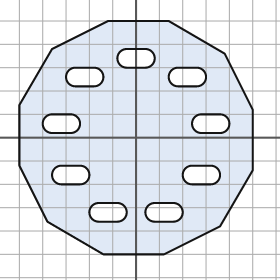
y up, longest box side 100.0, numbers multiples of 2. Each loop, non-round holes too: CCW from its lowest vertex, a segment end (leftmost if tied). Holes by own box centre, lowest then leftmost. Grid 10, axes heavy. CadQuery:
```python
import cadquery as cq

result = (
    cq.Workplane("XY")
    .moveTo(-14.0, -50.0)
    .lineTo(12.0, -50.0)
    .lineTo(36.0, -38.0)
    .lineTo(50.0, -14.0)
    .lineTo(50.0, 12.0)
    .lineTo(38.0, 36.0)
    .lineTo(14.0, 50.0)
    .lineTo(-12.0, 50.0)
    .lineTo(-36.0, 38.0)
    .lineTo(-50.0, 14.0)
    .lineTo(-50.0, -12.0)
    .lineTo(-38.0, -36.0)
    .close()
    .moveTo(-16.0, -36.0)
    .lineTo(-8.0, -36.0)
    .threePointArc((-4.0, -32.0), (-8.0, -28.0))
    .lineTo(-16.0, -28.0)
    .threePointArc((-20.0, -32.0), (-16.0, -36.0))
    .close()
    .moveTo(8.0, -36.0)
    .lineTo(16.0, -36.0)
    .threePointArc((20.0, -32.0), (16.0, -28.0))
    .lineTo(8.0, -28.0)
    .threePointArc((4.0, -32.0), (8.0, -36.0))
    .close()
    .moveTo(-32.0, -20.0)
    .lineTo(-24.0, -20.0)
    .threePointArc((-20.0, -16.0), (-24.0, -12.0))
    .lineTo(-32.0, -12.0)
    .threePointArc((-36.0, -16.0), (-32.0, -20.0))
    .close()
    .moveTo(24.0, -20.0)
    .lineTo(32.0, -20.0)
    .threePointArc((36.0, -16.0), (32.0, -12.0))
    .lineTo(24.0, -12.0)
    .threePointArc((20.0, -16.0), (24.0, -20.0))
    .close()
    .moveTo(-36.0, 2.0)
    .lineTo(-28.0, 2.0)
    .threePointArc((-24.0, 6.0), (-28.0, 10.0))
    .lineTo(-36.0, 10.0)
    .threePointArc((-40.0, 6.0), (-36.0, 2.0))
    .close()
    .moveTo(28.0, 2.0)
    .lineTo(36.0, 2.0)
    .threePointArc((40.0, 6.0), (36.0, 10.0))
    .lineTo(28.0, 10.0)
    .threePointArc((24.0, 6.0), (28.0, 2.0))
    .close()
    .moveTo(-26.0, 22.0)
    .lineTo(-18.0, 22.0)
    .threePointArc((-14.0, 26.0), (-18.0, 30.0))
    .lineTo(-26.0, 30.0)
    .threePointArc((-30.0, 26.0), (-26.0, 22.0))
    .close()
    .moveTo(18.0, 22.0)
    .lineTo(26.0, 22.0)
    .threePointArc((30.0, 26.0), (26.0, 30.0))
    .lineTo(18.0, 30.0)
    .threePointArc((14.0, 26.0), (18.0, 22.0))
    .close()
    .moveTo(-4.0, 30.0)
    .lineTo(4.0, 30.0)
    .threePointArc((8.0, 34.0), (4.0, 38.0))
    .lineTo(-4.0, 38.0)
    .threePointArc((-8.0, 34.0), (-4.0, 30.0))
    .close()
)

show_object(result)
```